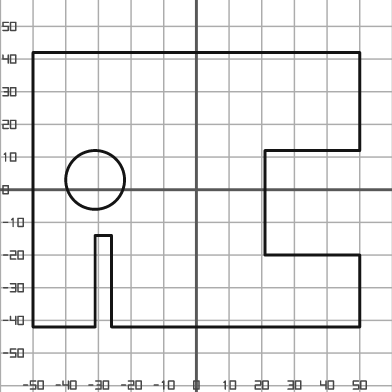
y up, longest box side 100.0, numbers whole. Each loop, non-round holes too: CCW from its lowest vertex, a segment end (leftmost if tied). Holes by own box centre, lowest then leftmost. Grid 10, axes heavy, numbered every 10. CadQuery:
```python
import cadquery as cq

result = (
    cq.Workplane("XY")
    .moveTo(-50.0, -42.0)
    .lineTo(-31.0, -42.0)
    .lineTo(-31.0, -14.0)
    .lineTo(-26.0, -14.0)
    .lineTo(-26.0, -42.0)
    .lineTo(50.0, -42.0)
    .lineTo(50.0, -20.0)
    .lineTo(21.0, -20.0)
    .lineTo(21.0, 12.0)
    .lineTo(50.0, 12.0)
    .lineTo(50.0, 42.0)
    .lineTo(-50.0, 42.0)
    .close()
    .moveTo(-31.0, 3.0)
    .circle(9.0)
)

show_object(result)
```